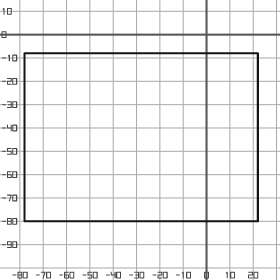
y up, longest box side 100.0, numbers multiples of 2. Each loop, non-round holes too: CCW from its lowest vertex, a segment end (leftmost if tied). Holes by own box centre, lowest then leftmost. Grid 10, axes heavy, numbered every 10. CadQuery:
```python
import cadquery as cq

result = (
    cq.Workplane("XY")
    .moveTo(-78.0, -80.0)
    .lineTo(22.0, -80.0)
    .lineTo(22.0, -8.0)
    .lineTo(-78.0, -8.0)
    .close()
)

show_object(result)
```